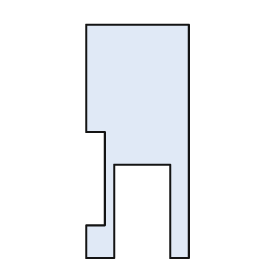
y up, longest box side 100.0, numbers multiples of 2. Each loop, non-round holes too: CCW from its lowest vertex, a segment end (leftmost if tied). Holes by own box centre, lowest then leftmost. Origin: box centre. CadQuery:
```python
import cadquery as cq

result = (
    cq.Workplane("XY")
    .moveTo(-22.0, -50.0)
    .lineTo(-10.0, -50.0)
    .lineTo(-10.0, -10.0)
    .lineTo(14.0, -10.0)
    .lineTo(14.0, -50.0)
    .lineTo(22.0, -50.0)
    .lineTo(22.0, 50.0)
    .lineTo(-22.0, 50.0)
    .lineTo(-22.0, 4.0)
    .lineTo(-14.0, 4.0)
    .lineTo(-14.0, -36.0)
    .lineTo(-22.0, -36.0)
    .close()
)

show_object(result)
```